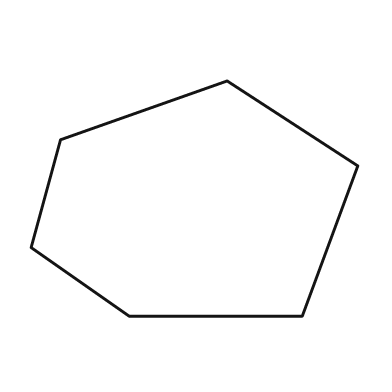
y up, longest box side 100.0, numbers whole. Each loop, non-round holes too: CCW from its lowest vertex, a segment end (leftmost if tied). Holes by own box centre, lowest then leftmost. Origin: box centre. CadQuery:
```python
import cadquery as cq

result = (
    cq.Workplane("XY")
    .moveTo(-20.0, -36.0)
    .lineTo(33.0, -36.0)
    .lineTo(50.0, 10.0)
    .lineTo(10.0, 36.0)
    .lineTo(-41.0, 18.0)
    .lineTo(-50.0, -15.0)
    .close()
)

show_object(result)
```